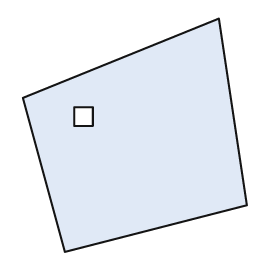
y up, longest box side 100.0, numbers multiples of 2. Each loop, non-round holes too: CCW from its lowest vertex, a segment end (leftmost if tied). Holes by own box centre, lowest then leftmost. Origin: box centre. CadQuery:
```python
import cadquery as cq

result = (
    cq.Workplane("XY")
    .moveTo(-30.0, -50.0)
    .lineTo(48.0, -30.0)
    .lineTo(36.0, 50.0)
    .lineTo(-48.0, 16.0)
    .close()
    .moveTo(-26.0, 4.0)
    .lineTo(-18.0, 4.0)
    .lineTo(-18.0, 12.0)
    .lineTo(-26.0, 12.0)
    .close()
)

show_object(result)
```